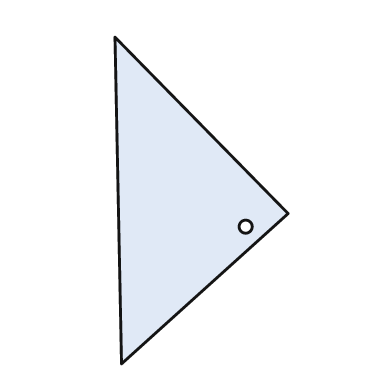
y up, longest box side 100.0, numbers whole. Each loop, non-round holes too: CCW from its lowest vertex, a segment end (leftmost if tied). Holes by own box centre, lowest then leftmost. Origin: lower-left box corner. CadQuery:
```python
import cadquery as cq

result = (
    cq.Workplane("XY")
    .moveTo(2.0, 0.0)
    .lineTo(53.0, 46.0)
    .lineTo(0.0, 100.0)
    .close()
    .moveTo(40.0, 42.0)
    .circle(2.0)
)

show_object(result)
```